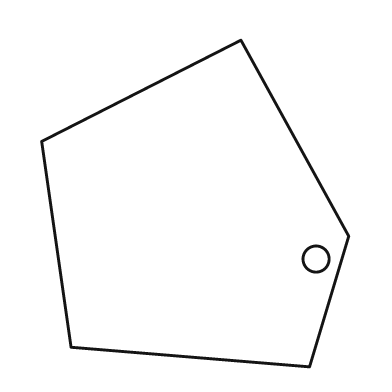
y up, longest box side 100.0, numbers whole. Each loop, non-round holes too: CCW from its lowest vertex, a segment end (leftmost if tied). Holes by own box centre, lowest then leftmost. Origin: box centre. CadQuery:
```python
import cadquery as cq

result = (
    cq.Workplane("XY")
    .moveTo(35.0, -50.0)
    .lineTo(47.0, -10.0)
    .lineTo(14.0, 50.0)
    .lineTo(-47.0, 19.0)
    .lineTo(-38.0, -44.0)
    .close()
    .moveTo(37.0, -17.0)
    .circle(4.0)
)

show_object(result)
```